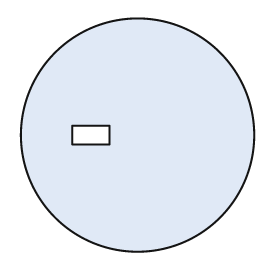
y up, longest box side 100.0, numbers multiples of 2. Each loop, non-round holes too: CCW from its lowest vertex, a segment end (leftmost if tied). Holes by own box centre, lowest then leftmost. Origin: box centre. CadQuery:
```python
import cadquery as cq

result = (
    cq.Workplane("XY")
    .moveTo(0.0, 0.0)
    .circle(50.0)
    .moveTo(-28.0, -4.0)
    .lineTo(-12.0, -4.0)
    .lineTo(-12.0, 4.0)
    .lineTo(-28.0, 4.0)
    .close()
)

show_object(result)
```